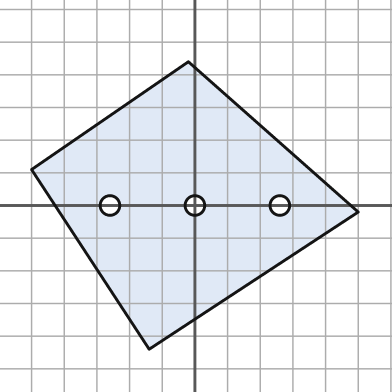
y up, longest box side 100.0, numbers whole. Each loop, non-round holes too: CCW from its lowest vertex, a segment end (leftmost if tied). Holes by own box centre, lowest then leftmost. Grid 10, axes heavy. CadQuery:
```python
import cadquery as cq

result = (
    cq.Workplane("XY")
    .moveTo(-14.0, -44.0)
    .lineTo(50.0, -2.0)
    .lineTo(-2.0, 44.0)
    .lineTo(-50.0, 11.0)
    .close()
    .moveTo(-26.0, 0.0)
    .circle(3.0)
    .moveTo(0.0, 0.0)
    .circle(3.0)
    .moveTo(26.0, 0.0)
    .circle(3.0)
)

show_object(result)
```